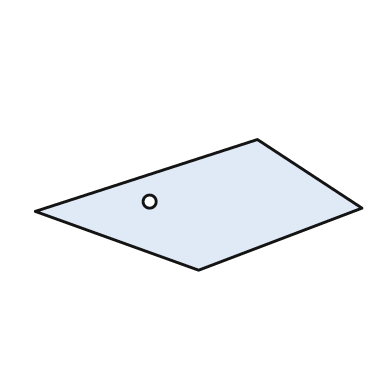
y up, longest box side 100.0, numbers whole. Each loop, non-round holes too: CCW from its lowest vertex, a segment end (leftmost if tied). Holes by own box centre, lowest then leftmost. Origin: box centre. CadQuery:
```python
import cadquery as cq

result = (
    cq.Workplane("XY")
    .moveTo(0.0, -20.0)
    .lineTo(50.0, -1.0)
    .lineTo(18.0, 20.0)
    .lineTo(-50.0, -2.0)
    .close()
    .moveTo(-15.0, 1.0)
    .circle(2.0)
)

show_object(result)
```